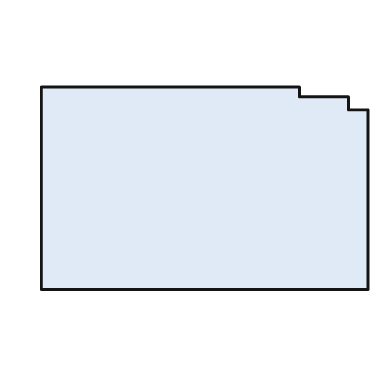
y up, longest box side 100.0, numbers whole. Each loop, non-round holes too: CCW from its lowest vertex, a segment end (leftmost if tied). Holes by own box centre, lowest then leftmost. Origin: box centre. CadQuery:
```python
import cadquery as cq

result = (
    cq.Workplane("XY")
    .moveTo(-50.0, -31.0)
    .lineTo(50.0, -31.0)
    .lineTo(50.0, 24.0)
    .lineTo(44.0, 24.0)
    .lineTo(44.0, 28.0)
    .lineTo(29.0, 28.0)
    .lineTo(29.0, 31.0)
    .lineTo(-50.0, 31.0)
    .close()
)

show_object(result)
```